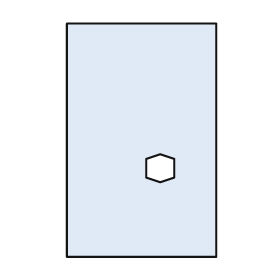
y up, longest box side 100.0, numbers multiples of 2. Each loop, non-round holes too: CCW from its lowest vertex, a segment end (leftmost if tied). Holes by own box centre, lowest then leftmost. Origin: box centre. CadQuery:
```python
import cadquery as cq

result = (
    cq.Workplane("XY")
    .moveTo(-32.0, -50.0)
    .lineTo(32.0, -50.0)
    .lineTo(32.0, 50.0)
    .lineTo(-32.0, 50.0)
    .close()
    .moveTo(8.0, -18.0)
    .lineTo(14.0, -16.0)
    .lineTo(14.0, -8.0)
    .lineTo(8.0, -6.0)
    .lineTo(2.0, -8.0)
    .lineTo(2.0, -16.0)
    .close()
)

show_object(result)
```